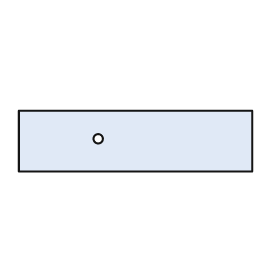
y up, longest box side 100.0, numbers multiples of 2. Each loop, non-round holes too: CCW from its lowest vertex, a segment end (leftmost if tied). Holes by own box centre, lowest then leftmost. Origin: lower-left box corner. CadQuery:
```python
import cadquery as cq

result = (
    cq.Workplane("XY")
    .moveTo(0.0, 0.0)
    .lineTo(100.0, 0.0)
    .lineTo(100.0, 26.0)
    .lineTo(0.0, 26.0)
    .close()
    .moveTo(34.0, 14.0)
    .circle(2.0)
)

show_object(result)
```